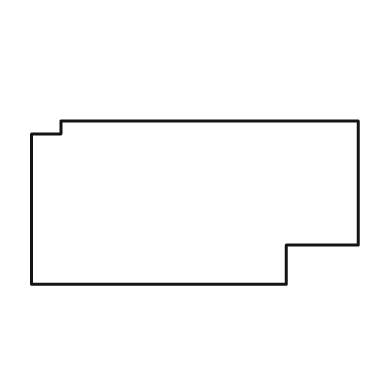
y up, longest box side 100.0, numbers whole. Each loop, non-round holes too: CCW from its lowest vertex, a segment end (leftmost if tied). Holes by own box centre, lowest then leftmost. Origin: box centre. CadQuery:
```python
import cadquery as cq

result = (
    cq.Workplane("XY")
    .moveTo(-50.0, -25.0)
    .lineTo(28.0, -25.0)
    .lineTo(28.0, -13.0)
    .lineTo(50.0, -13.0)
    .lineTo(50.0, 25.0)
    .lineTo(-41.0, 25.0)
    .lineTo(-41.0, 21.0)
    .lineTo(-50.0, 21.0)
    .close()
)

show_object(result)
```